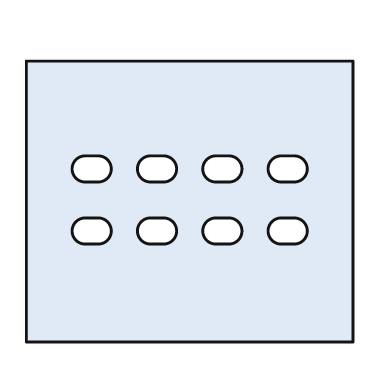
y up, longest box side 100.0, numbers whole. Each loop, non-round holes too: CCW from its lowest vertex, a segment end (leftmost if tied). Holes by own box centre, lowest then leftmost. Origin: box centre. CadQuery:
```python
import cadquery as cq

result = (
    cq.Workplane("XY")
    .moveTo(-50.0, -43.0)
    .lineTo(50.0, -43.0)
    .lineTo(50.0, 43.0)
    .lineTo(-50.0, 43.0)
    .close()
    .moveTo(-32.0, -13.0)
    .lineTo(-28.0, -13.0)
    .threePointArc((-24.0, -9.0), (-28.0, -5.0))
    .lineTo(-32.0, -5.0)
    .threePointArc((-36.0, -9.0), (-32.0, -13.0))
    .close()
    .moveTo(-12.0, -13.0)
    .lineTo(-8.0, -13.0)
    .threePointArc((-4.0, -9.0), (-8.0, -5.0))
    .lineTo(-12.0, -5.0)
    .threePointArc((-16.0, -9.0), (-12.0, -13.0))
    .close()
    .moveTo(8.0, -13.0)
    .lineTo(12.0, -13.0)
    .threePointArc((16.0, -9.0), (12.0, -5.0))
    .lineTo(8.0, -5.0)
    .threePointArc((4.0, -9.0), (8.0, -13.0))
    .close()
    .moveTo(28.0, -13.0)
    .lineTo(32.0, -13.0)
    .threePointArc((36.0, -9.0), (32.0, -5.0))
    .lineTo(28.0, -5.0)
    .threePointArc((24.0, -9.0), (28.0, -13.0))
    .close()
    .moveTo(-32.0, 6.0)
    .lineTo(-28.0, 6.0)
    .threePointArc((-24.0, 10.0), (-28.0, 14.0))
    .lineTo(-32.0, 14.0)
    .threePointArc((-36.0, 10.0), (-32.0, 6.0))
    .close()
    .moveTo(-12.0, 6.0)
    .lineTo(-8.0, 6.0)
    .threePointArc((-4.0, 10.0), (-8.0, 14.0))
    .lineTo(-12.0, 14.0)
    .threePointArc((-16.0, 10.0), (-12.0, 6.0))
    .close()
    .moveTo(8.0, 6.0)
    .lineTo(12.0, 6.0)
    .threePointArc((16.0, 10.0), (12.0, 14.0))
    .lineTo(8.0, 14.0)
    .threePointArc((4.0, 10.0), (8.0, 6.0))
    .close()
    .moveTo(28.0, 6.0)
    .lineTo(32.0, 6.0)
    .threePointArc((36.0, 10.0), (32.0, 14.0))
    .lineTo(28.0, 14.0)
    .threePointArc((24.0, 10.0), (28.0, 6.0))
    .close()
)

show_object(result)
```